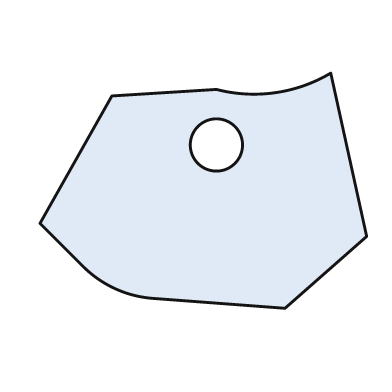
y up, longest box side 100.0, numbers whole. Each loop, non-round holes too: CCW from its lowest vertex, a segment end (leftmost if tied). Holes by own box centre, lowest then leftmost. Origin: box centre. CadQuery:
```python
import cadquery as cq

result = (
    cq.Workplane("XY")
    .moveTo(25.0, -36.0)
    .lineTo(50.0, -14.0)
    .lineTo(39.0, 36.0)
    .threePointArc((22.0, 30.0), (4.0, 31.0))
    .lineTo(-28.0, 29.0)
    .lineTo(-50.0, -10.0)
    .lineTo(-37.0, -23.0)
    .threePointArc((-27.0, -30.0), (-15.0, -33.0))
    .close()
    .moveTo(4.0, 14.0)
    .circle(8.0)
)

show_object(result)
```